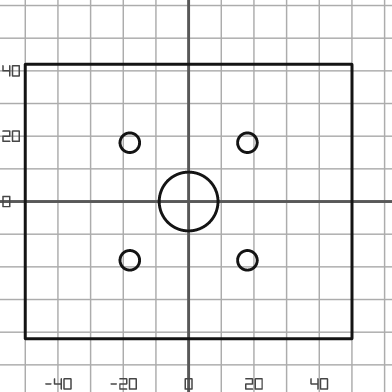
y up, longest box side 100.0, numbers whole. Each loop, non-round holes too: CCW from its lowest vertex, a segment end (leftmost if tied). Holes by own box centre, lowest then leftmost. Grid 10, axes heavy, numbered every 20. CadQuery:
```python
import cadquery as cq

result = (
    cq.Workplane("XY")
    .moveTo(-50.0, -42.0)
    .lineTo(50.0, -42.0)
    .lineTo(50.0, 42.0)
    .lineTo(-50.0, 42.0)
    .close()
    .moveTo(-18.0, -18.0)
    .circle(3.0)
    .moveTo(18.0, -18.0)
    .circle(3.0)
    .moveTo(0.0, 0.0)
    .circle(9.0)
    .moveTo(-18.0, 18.0)
    .circle(3.0)
    .moveTo(18.0, 18.0)
    .circle(3.0)
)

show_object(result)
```